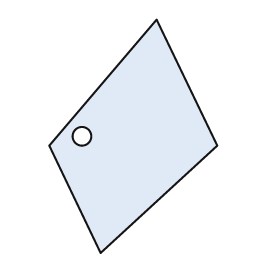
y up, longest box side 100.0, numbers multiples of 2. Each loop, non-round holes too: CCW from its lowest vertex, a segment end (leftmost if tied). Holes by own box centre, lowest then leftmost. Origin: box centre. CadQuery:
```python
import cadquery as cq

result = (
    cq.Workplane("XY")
    .moveTo(-14.0, -50.0)
    .lineTo(36.0, -4.0)
    .lineTo(10.0, 50.0)
    .lineTo(-36.0, -4.0)
    .close()
    .moveTo(-22.0, 0.0)
    .circle(4.0)
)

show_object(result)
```